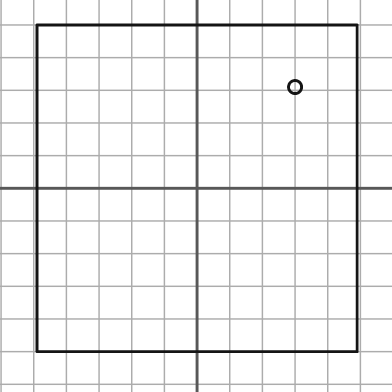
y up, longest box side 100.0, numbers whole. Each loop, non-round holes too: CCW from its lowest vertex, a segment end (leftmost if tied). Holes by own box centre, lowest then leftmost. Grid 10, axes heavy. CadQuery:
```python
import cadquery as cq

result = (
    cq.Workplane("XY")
    .moveTo(-49.0, -50.0)
    .lineTo(49.0, -50.0)
    .lineTo(49.0, 50.0)
    .lineTo(-49.0, 50.0)
    .close()
    .moveTo(30.0, 31.0)
    .circle(2.0)
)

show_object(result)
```